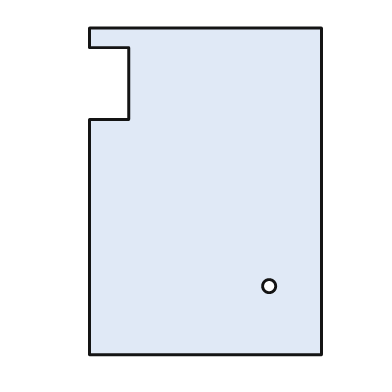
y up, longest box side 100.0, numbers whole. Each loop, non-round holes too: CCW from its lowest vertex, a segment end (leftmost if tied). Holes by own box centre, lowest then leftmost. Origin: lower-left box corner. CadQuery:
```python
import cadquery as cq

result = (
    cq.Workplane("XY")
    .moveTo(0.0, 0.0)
    .lineTo(71.0, 0.0)
    .lineTo(71.0, 100.0)
    .lineTo(0.0, 100.0)
    .lineTo(0.0, 94.0)
    .lineTo(12.0, 94.0)
    .lineTo(12.0, 72.0)
    .lineTo(0.0, 72.0)
    .close()
    .moveTo(55.0, 21.0)
    .circle(2.0)
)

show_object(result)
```